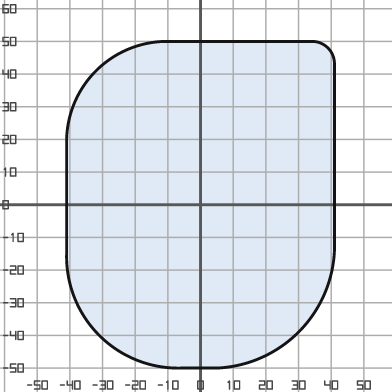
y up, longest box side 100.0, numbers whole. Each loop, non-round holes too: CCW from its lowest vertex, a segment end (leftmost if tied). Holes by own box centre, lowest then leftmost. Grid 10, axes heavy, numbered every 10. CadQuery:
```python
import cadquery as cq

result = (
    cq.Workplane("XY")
    .moveTo(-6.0, -50.0)
    .lineTo(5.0, -50.0)
    .threePointArc((30.0, -39.0), (41.0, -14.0))
    .lineTo(41.0, 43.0)
    .threePointArc((39.0, 48.0), (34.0, 50.0))
    .lineTo(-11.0, 50.0)
    .threePointArc((-32.0, 41.0), (-41.0, 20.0))
    .lineTo(-41.0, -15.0)
    .threePointArc((-31.0, -40.0), (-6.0, -50.0))
    .close()
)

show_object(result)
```